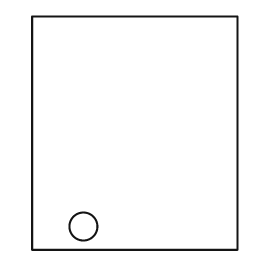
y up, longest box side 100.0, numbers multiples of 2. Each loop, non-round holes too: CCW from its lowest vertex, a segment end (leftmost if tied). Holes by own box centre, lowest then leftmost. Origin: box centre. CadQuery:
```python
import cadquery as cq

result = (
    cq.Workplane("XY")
    .moveTo(-44.0, -50.0)
    .lineTo(44.0, -50.0)
    .lineTo(44.0, 50.0)
    .lineTo(-44.0, 50.0)
    .close()
    .moveTo(-22.0, -40.0)
    .circle(6.0)
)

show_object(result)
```